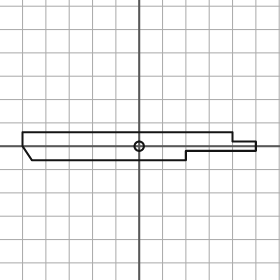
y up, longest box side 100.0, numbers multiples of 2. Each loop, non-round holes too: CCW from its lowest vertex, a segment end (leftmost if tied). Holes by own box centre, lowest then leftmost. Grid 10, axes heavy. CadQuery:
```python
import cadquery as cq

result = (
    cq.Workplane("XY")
    .moveTo(-46.0, -6.0)
    .lineTo(20.0, -6.0)
    .lineTo(20.0, -2.0)
    .lineTo(50.0, -2.0)
    .lineTo(50.0, 2.0)
    .lineTo(40.0, 2.0)
    .lineTo(40.0, 6.0)
    .lineTo(-50.0, 6.0)
    .lineTo(-50.0, 0.0)
    .close()
    .moveTo(0.0, 0.0)
    .circle(2.0)
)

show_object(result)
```